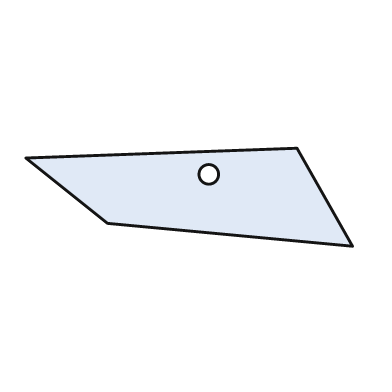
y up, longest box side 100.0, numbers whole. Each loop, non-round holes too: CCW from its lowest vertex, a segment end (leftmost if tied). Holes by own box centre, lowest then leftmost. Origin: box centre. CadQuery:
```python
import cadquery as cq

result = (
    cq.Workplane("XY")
    .moveTo(50.0, -15.0)
    .lineTo(33.0, 15.0)
    .lineTo(-50.0, 12.0)
    .lineTo(-25.0, -8.0)
    .close()
    .moveTo(6.0, 7.0)
    .circle(3.0)
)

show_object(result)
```